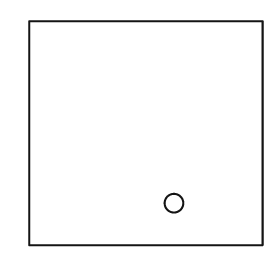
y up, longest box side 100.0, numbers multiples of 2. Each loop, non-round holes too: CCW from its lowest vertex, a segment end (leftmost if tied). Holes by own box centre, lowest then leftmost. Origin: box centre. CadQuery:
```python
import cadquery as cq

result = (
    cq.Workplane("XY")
    .moveTo(-50.0, -48.0)
    .lineTo(50.0, -48.0)
    .lineTo(50.0, 48.0)
    .lineTo(-50.0, 48.0)
    .close()
    .moveTo(12.0, -30.0)
    .circle(4.0)
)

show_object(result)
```